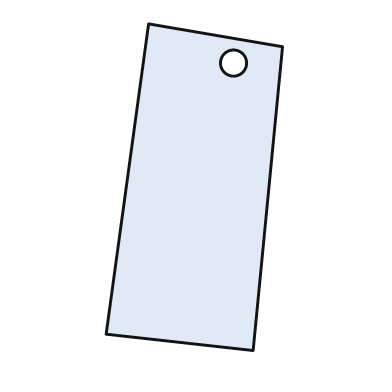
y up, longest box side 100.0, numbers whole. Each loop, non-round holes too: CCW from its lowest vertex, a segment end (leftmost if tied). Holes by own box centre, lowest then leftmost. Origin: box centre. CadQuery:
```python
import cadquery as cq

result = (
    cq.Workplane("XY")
    .moveTo(18.0, -50.0)
    .lineTo(27.0, 43.0)
    .lineTo(-14.0, 50.0)
    .lineTo(-27.0, -45.0)
    .close()
    .moveTo(12.0, 38.0)
    .circle(4.0)
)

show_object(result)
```